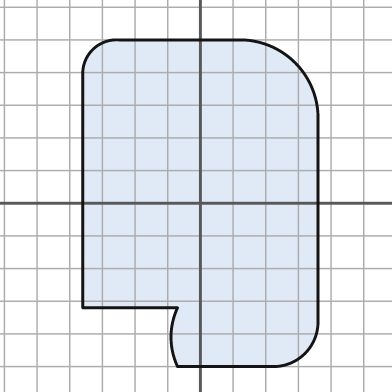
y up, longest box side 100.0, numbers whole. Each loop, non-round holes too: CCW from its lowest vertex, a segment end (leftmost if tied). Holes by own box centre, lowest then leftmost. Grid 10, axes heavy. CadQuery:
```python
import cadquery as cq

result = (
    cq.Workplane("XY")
    .moveTo(-7.0, -50.0)
    .lineTo(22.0, -50.0)
    .threePointArc((32.0, -46.0), (36.0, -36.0))
    .lineTo(36.0, 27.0)
    .threePointArc((29.0, 43.0), (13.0, 50.0))
    .lineTo(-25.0, 50.0)
    .threePointArc((-33.0, 47.0), (-36.0, 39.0))
    .lineTo(-36.0, -32.0)
    .lineTo(-7.0, -32.0)
    .threePointArc((-9.0, -41.0), (-7.0, -50.0))
    .close()
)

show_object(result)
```